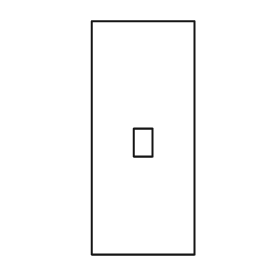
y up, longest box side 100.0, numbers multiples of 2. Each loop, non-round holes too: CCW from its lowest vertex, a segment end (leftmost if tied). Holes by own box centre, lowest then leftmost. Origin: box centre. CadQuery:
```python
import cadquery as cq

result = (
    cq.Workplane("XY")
    .moveTo(-22.0, -50.0)
    .lineTo(22.0, -50.0)
    .lineTo(22.0, 50.0)
    .lineTo(-22.0, 50.0)
    .close()
    .moveTo(-4.0, -8.0)
    .lineTo(4.0, -8.0)
    .lineTo(4.0, 4.0)
    .lineTo(-4.0, 4.0)
    .close()
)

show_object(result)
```